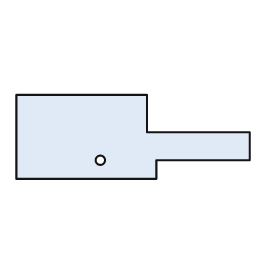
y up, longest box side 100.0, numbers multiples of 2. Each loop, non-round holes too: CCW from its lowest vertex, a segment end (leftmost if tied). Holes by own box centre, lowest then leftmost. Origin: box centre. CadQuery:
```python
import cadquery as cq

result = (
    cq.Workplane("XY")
    .moveTo(-50.0, -18.0)
    .lineTo(10.0, -18.0)
    .lineTo(10.0, -10.0)
    .lineTo(50.0, -10.0)
    .lineTo(50.0, 2.0)
    .lineTo(6.0, 2.0)
    .lineTo(6.0, 18.0)
    .lineTo(-50.0, 18.0)
    .close()
    .moveTo(-14.0, -10.0)
    .circle(2.0)
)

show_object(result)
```